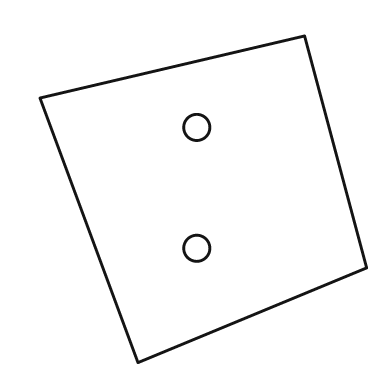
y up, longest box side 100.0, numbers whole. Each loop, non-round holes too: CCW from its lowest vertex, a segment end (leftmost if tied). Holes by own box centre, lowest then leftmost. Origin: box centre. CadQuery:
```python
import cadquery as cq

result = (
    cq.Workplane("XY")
    .moveTo(-20.0, -50.0)
    .lineTo(50.0, -21.0)
    .lineTo(31.0, 50.0)
    .lineTo(-50.0, 31.0)
    .close()
    .moveTo(-2.0, -15.0)
    .circle(4.0)
    .moveTo(-2.0, 22.0)
    .circle(4.0)
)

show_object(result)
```